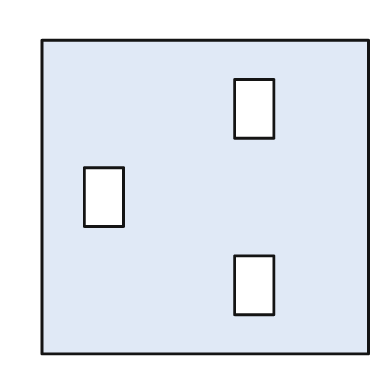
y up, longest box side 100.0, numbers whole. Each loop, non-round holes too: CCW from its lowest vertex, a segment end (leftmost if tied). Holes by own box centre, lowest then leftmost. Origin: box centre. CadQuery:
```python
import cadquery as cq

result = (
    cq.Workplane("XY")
    .moveTo(-50.0, -48.0)
    .lineTo(50.0, -48.0)
    .lineTo(50.0, 48.0)
    .lineTo(-50.0, 48.0)
    .close()
    .moveTo(9.0, -36.0)
    .lineTo(21.0, -36.0)
    .lineTo(21.0, -18.0)
    .lineTo(9.0, -18.0)
    .close()
    .moveTo(-37.0, -9.0)
    .lineTo(-25.0, -9.0)
    .lineTo(-25.0, 9.0)
    .lineTo(-37.0, 9.0)
    .close()
    .moveTo(9.0, 18.0)
    .lineTo(21.0, 18.0)
    .lineTo(21.0, 36.0)
    .lineTo(9.0, 36.0)
    .close()
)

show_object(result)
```